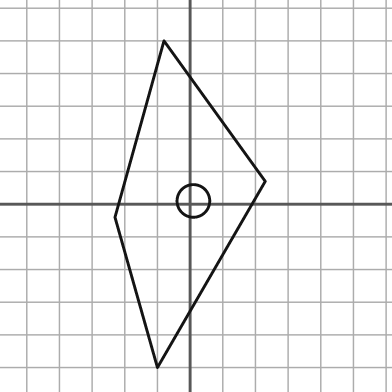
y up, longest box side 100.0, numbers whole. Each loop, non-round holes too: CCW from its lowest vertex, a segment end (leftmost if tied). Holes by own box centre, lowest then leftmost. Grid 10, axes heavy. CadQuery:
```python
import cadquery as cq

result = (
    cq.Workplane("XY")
    .moveTo(-10.0, -50.0)
    .lineTo(23.0, 7.0)
    .lineTo(-8.0, 50.0)
    .lineTo(-23.0, -4.0)
    .close()
    .moveTo(1.0, 1.0)
    .circle(5.0)
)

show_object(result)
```